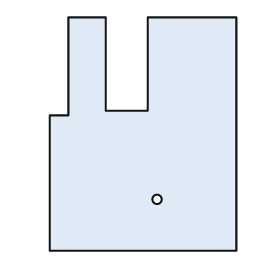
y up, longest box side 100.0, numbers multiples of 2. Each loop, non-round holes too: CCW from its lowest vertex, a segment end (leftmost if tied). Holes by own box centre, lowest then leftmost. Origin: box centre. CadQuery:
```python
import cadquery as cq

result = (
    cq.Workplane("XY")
    .moveTo(-40.0, -50.0)
    .lineTo(40.0, -50.0)
    .lineTo(40.0, 50.0)
    .lineTo(2.0, 50.0)
    .lineTo(2.0, 10.0)
    .lineTo(-16.0, 10.0)
    .lineTo(-16.0, 50.0)
    .lineTo(-32.0, 50.0)
    .lineTo(-32.0, 8.0)
    .lineTo(-40.0, 8.0)
    .close()
    .moveTo(6.0, -28.0)
    .circle(2.0)
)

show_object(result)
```